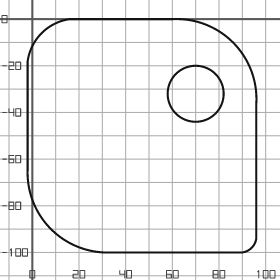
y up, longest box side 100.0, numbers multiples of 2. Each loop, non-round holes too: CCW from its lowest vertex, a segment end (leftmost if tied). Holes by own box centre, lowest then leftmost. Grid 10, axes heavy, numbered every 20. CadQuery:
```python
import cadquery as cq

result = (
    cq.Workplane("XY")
    .moveTo(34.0, -100.0)
    .lineTo(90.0, -100.0)
    .threePointArc((94.0, -98.0), (96.0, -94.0))
    .lineTo(96.0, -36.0)
    .threePointArc((86.0, -10.0), (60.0, 0.0))
    .lineTo(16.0, 0.0)
    .threePointArc((4.0, -6.0), (-2.0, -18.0))
    .lineTo(-2.0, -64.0)
    .threePointArc((8.0, -90.0), (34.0, -100.0))
    .close()
    .moveTo(70.0, -32.0)
    .circle(12.0)
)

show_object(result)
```